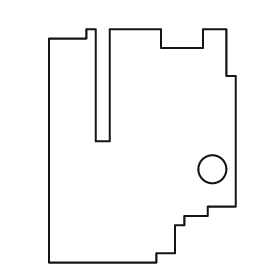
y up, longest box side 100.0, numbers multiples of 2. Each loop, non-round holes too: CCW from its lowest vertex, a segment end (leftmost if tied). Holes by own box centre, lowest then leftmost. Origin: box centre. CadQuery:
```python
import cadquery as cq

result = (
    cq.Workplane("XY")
    .moveTo(-40.0, -50.0)
    .lineTo(6.0, -50.0)
    .lineTo(6.0, -46.0)
    .lineTo(14.0, -46.0)
    .lineTo(14.0, -34.0)
    .lineTo(18.0, -34.0)
    .lineTo(18.0, -30.0)
    .lineTo(28.0, -30.0)
    .lineTo(28.0, -26.0)
    .lineTo(40.0, -26.0)
    .lineTo(40.0, 30.0)
    .lineTo(36.0, 30.0)
    .lineTo(36.0, 50.0)
    .lineTo(26.0, 50.0)
    .lineTo(26.0, 42.0)
    .lineTo(8.0, 42.0)
    .lineTo(8.0, 50.0)
    .lineTo(-14.0, 50.0)
    .lineTo(-14.0, 2.0)
    .lineTo(-20.0, 2.0)
    .lineTo(-20.0, 50.0)
    .lineTo(-24.0, 50.0)
    .lineTo(-24.0, 46.0)
    .lineTo(-40.0, 46.0)
    .close()
    .moveTo(30.0, -10.0)
    .circle(6.0)
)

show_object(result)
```